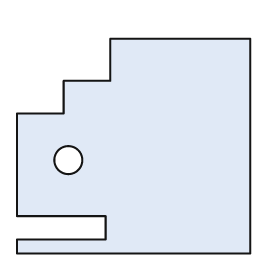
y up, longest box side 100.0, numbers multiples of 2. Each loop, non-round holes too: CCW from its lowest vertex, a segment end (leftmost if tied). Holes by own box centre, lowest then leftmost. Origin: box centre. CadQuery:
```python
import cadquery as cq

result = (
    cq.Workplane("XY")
    .moveTo(-50.0, -46.0)
    .lineTo(50.0, -46.0)
    .lineTo(50.0, 46.0)
    .lineTo(-10.0, 46.0)
    .lineTo(-10.0, 28.0)
    .lineTo(-30.0, 28.0)
    .lineTo(-30.0, 14.0)
    .lineTo(-50.0, 14.0)
    .lineTo(-50.0, -30.0)
    .lineTo(-12.0, -30.0)
    .lineTo(-12.0, -40.0)
    .lineTo(-50.0, -40.0)
    .close()
    .moveTo(-28.0, -6.0)
    .circle(6.0)
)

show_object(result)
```